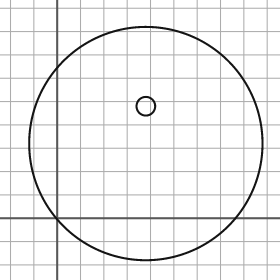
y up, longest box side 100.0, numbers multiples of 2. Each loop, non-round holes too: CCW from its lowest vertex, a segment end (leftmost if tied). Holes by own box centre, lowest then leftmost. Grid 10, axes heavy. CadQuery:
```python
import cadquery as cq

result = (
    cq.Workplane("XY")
    .moveTo(38.0, 32.0)
    .circle(50.0)
    .moveTo(38.0, 48.0)
    .circle(4.0)
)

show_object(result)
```